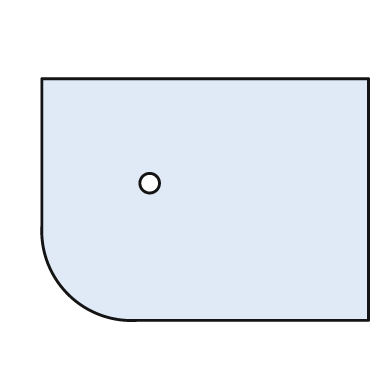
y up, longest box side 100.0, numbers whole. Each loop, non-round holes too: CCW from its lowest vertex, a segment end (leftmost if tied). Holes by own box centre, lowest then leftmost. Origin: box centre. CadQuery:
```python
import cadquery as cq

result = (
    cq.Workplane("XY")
    .moveTo(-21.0, -37.0)
    .lineTo(50.0, -37.0)
    .lineTo(50.0, 37.0)
    .lineTo(-50.0, 37.0)
    .lineTo(-50.0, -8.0)
    .threePointArc((-42.0, -29.0), (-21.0, -37.0))
    .close()
    .moveTo(-17.0, 5.0)
    .circle(3.0)
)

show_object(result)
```